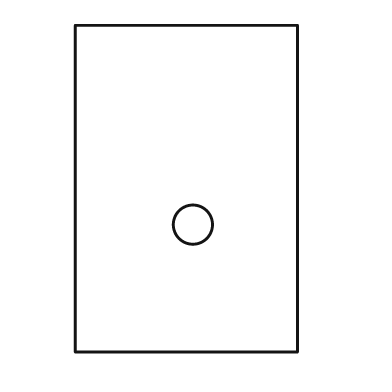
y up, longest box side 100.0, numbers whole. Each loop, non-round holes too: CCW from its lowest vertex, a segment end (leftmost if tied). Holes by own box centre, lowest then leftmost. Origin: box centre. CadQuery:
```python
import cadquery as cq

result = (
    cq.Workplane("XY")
    .moveTo(-34.0, -50.0)
    .lineTo(34.0, -50.0)
    .lineTo(34.0, 50.0)
    .lineTo(-34.0, 50.0)
    .close()
    .moveTo(2.0, -11.0)
    .circle(6.0)
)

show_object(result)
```